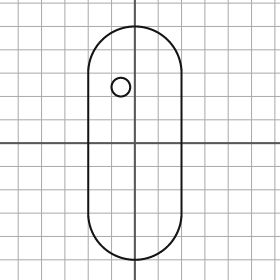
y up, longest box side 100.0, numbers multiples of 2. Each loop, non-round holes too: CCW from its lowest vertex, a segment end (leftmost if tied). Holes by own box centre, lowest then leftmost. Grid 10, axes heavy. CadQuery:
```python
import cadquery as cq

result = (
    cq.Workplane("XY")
    .moveTo(-20.0, -30.0)
    .threePointArc((0.0, -50.0), (20.0, -30.0))
    .lineTo(20.0, 30.0)
    .threePointArc((0.0, 50.0), (-20.0, 30.0))
    .close()
    .moveTo(-6.0, 24.0)
    .circle(4.0)
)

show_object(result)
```